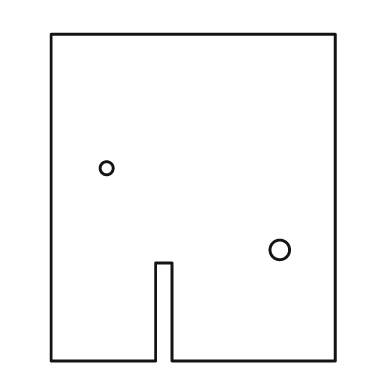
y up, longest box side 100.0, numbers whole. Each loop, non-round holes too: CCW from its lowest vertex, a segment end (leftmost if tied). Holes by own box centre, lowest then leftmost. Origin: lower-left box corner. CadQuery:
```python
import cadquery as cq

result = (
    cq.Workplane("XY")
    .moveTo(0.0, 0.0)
    .lineTo(32.0, 0.0)
    .lineTo(32.0, 30.0)
    .lineTo(37.0, 30.0)
    .lineTo(37.0, 0.0)
    .lineTo(87.0, 0.0)
    .lineTo(87.0, 100.0)
    .lineTo(0.0, 100.0)
    .close()
    .moveTo(70.0, 34.0)
    .circle(3.0)
    .moveTo(17.0, 59.0)
    .circle(2.0)
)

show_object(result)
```